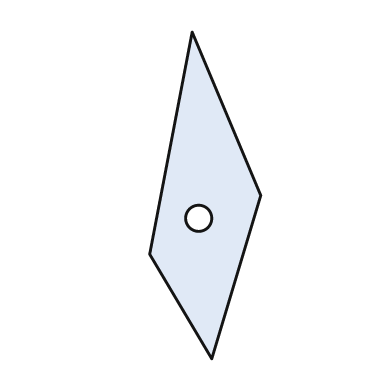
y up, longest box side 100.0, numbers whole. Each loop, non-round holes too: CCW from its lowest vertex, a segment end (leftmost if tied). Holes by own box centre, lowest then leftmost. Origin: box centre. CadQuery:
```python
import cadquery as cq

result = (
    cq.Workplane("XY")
    .moveTo(2.0, -50.0)
    .lineTo(17.0, 0.0)
    .lineTo(-4.0, 50.0)
    .lineTo(-17.0, -18.0)
    .close()
    .moveTo(-2.0, -7.0)
    .circle(4.0)
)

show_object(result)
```